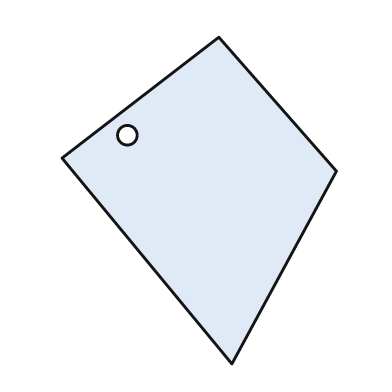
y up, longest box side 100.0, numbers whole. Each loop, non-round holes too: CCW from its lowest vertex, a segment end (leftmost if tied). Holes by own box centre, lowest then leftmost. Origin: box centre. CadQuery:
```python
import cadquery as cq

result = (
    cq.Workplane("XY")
    .moveTo(10.0, -50.0)
    .lineTo(42.0, 9.0)
    .lineTo(6.0, 50.0)
    .lineTo(-42.0, 13.0)
    .close()
    .moveTo(-22.0, 20.0)
    .circle(3.0)
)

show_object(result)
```